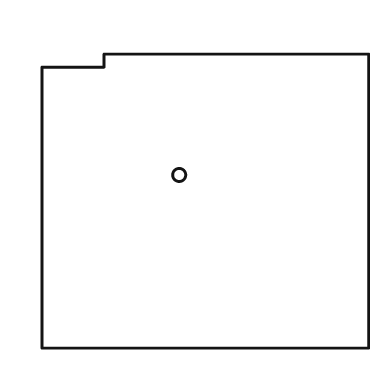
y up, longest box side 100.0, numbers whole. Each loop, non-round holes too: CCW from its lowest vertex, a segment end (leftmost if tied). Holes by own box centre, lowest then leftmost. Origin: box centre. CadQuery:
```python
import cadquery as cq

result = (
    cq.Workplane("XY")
    .moveTo(-50.0, -45.0)
    .lineTo(50.0, -45.0)
    .lineTo(50.0, 45.0)
    .lineTo(-31.0, 45.0)
    .lineTo(-31.0, 41.0)
    .lineTo(-50.0, 41.0)
    .close()
    .moveTo(-8.0, 8.0)
    .circle(2.0)
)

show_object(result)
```